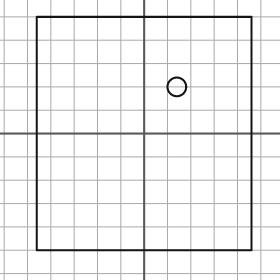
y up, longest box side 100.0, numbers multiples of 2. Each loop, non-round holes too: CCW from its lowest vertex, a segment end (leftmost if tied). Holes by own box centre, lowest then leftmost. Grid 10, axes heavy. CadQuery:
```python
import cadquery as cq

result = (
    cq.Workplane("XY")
    .moveTo(-46.0, -50.0)
    .lineTo(46.0, -50.0)
    .lineTo(46.0, 50.0)
    .lineTo(-46.0, 50.0)
    .close()
    .moveTo(14.0, 20.0)
    .circle(4.0)
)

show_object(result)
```